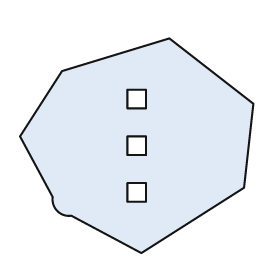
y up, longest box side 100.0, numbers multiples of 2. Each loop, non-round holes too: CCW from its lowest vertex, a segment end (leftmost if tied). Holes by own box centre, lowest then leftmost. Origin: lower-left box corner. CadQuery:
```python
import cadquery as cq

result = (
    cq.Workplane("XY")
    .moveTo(52.0, 0.0)
    .lineTo(96.0, 28.0)
    .lineTo(100.0, 64.0)
    .lineTo(64.0, 92.0)
    .lineTo(18.0, 78.0)
    .lineTo(0.0, 50.0)
    .lineTo(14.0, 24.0)
    .threePointArc((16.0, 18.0), (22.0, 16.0))
    .close()
    .moveTo(46.0, 22.0)
    .lineTo(54.0, 22.0)
    .lineTo(54.0, 30.0)
    .lineTo(46.0, 30.0)
    .close()
    .moveTo(46.0, 42.0)
    .lineTo(54.0, 42.0)
    .lineTo(54.0, 50.0)
    .lineTo(46.0, 50.0)
    .close()
    .moveTo(46.0, 62.0)
    .lineTo(54.0, 62.0)
    .lineTo(54.0, 70.0)
    .lineTo(46.0, 70.0)
    .close()
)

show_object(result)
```